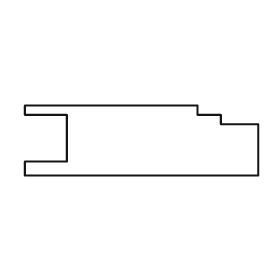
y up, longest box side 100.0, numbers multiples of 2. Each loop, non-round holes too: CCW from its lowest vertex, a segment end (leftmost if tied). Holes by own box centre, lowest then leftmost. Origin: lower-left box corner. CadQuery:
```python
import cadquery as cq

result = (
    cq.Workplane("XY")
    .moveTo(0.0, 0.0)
    .lineTo(100.0, 0.0)
    .lineTo(100.0, 22.0)
    .lineTo(84.0, 22.0)
    .lineTo(84.0, 26.0)
    .lineTo(74.0, 26.0)
    .lineTo(74.0, 30.0)
    .lineTo(0.0, 30.0)
    .lineTo(0.0, 26.0)
    .lineTo(18.0, 26.0)
    .lineTo(18.0, 6.0)
    .lineTo(0.0, 6.0)
    .close()
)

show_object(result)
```